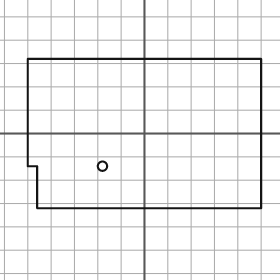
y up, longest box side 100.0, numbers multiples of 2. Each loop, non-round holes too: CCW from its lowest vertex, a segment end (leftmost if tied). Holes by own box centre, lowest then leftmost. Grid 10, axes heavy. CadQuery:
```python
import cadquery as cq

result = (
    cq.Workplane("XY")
    .moveTo(-46.0, -32.0)
    .lineTo(50.0, -32.0)
    .lineTo(50.0, 32.0)
    .lineTo(-50.0, 32.0)
    .lineTo(-50.0, -14.0)
    .lineTo(-46.0, -14.0)
    .close()
    .moveTo(-18.0, -14.0)
    .circle(2.0)
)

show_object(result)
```